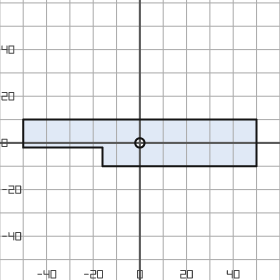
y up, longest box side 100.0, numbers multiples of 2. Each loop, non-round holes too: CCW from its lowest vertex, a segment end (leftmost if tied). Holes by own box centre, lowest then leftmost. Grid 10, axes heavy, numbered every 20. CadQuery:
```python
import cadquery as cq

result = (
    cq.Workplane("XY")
    .moveTo(-16.0, -10.0)
    .lineTo(50.0, -10.0)
    .lineTo(50.0, 10.0)
    .lineTo(-50.0, 10.0)
    .lineTo(-50.0, -2.0)
    .lineTo(-16.0, -2.0)
    .close()
    .moveTo(0.0, 0.0)
    .circle(2.0)
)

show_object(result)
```